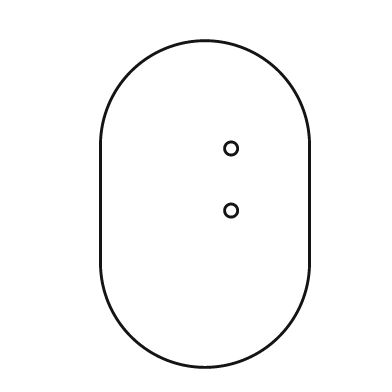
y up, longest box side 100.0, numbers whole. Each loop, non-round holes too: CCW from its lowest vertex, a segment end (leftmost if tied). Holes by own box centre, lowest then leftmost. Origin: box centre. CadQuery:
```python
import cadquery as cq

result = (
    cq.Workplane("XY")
    .moveTo(-32.0, -18.0)
    .threePointArc((0.0, -50.0), (32.0, -18.0))
    .lineTo(32.0, 18.0)
    .threePointArc((0.0, 50.0), (-32.0, 18.0))
    .close()
    .moveTo(8.0, -2.0)
    .circle(2.0)
    .moveTo(8.0, 17.0)
    .circle(2.0)
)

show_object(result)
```